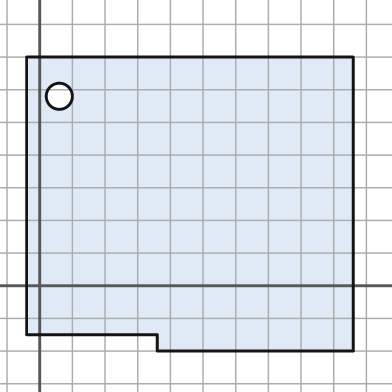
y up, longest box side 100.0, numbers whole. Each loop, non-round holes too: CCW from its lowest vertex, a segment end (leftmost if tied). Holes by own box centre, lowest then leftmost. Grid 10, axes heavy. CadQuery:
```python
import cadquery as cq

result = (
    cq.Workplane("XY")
    .moveTo(36.0, -20.0)
    .lineTo(96.0, -20.0)
    .lineTo(96.0, 70.0)
    .lineTo(-4.0, 70.0)
    .lineTo(-4.0, -15.0)
    .lineTo(36.0, -15.0)
    .close()
    .moveTo(6.0, 58.0)
    .circle(4.0)
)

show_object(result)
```